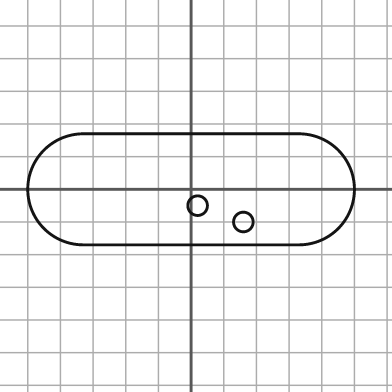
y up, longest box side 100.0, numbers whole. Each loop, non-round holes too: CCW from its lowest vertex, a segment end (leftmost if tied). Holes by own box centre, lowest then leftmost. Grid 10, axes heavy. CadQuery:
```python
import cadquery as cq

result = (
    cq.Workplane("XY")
    .moveTo(-33.0, -17.0)
    .lineTo(33.0, -17.0)
    .threePointArc((50.0, 0.0), (33.0, 17.0))
    .lineTo(-33.0, 17.0)
    .threePointArc((-50.0, 0.0), (-33.0, -17.0))
    .close()
    .moveTo(16.0, -10.0)
    .circle(3.0)
    .moveTo(2.0, -5.0)
    .circle(3.0)
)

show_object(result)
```